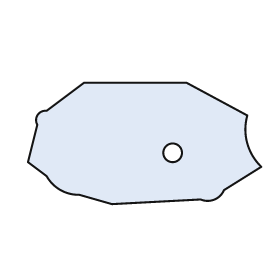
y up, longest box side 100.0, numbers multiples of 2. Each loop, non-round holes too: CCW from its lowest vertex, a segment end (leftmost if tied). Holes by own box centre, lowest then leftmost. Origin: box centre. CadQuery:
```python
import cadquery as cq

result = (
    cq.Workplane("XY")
    .moveTo(-14.0, -26.0)
    .lineTo(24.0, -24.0)
    .threePointArc((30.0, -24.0), (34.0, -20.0))
    .lineTo(50.0, -10.0)
    .threePointArc((44.0, 0.0), (44.0, 12.0))
    .lineTo(18.0, 26.0)
    .lineTo(-26.0, 26.0)
    .lineTo(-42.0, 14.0)
    .threePointArc((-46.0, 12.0), (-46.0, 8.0))
    .lineTo(-50.0, -8.0)
    .lineTo(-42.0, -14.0)
    .threePointArc((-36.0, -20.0), (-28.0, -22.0))
    .close()
    .moveTo(12.0, -4.0)
    .circle(4.0)
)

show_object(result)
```